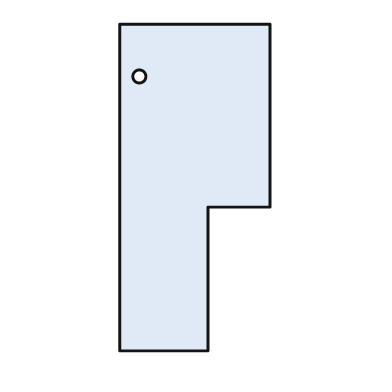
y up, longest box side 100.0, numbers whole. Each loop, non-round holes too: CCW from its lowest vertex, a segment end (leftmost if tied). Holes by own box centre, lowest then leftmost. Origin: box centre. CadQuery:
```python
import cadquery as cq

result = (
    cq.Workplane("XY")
    .moveTo(-23.0, -50.0)
    .lineTo(4.0, -50.0)
    .lineTo(4.0, -6.0)
    .lineTo(23.0, -6.0)
    .lineTo(23.0, 50.0)
    .lineTo(-23.0, 50.0)
    .close()
    .moveTo(-17.0, 34.0)
    .circle(2.0)
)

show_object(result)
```